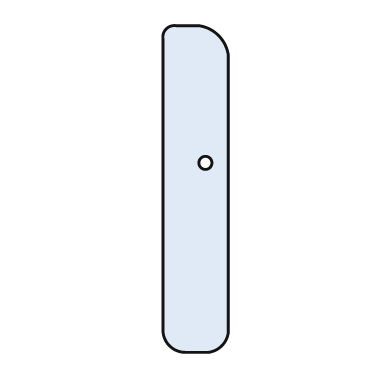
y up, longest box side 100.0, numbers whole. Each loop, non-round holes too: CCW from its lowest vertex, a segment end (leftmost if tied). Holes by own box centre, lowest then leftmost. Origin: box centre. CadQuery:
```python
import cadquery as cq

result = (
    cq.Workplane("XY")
    .moveTo(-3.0, -50.0)
    .lineTo(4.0, -50.0)
    .threePointArc((8.0, -48.0), (10.0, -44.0))
    .lineTo(10.0, 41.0)
    .threePointArc((7.0, 47.0), (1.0, 50.0))
    .lineTo(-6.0, 50.0)
    .threePointArc((-9.0, 49.0), (-10.0, 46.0))
    .lineTo(-10.0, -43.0)
    .threePointArc((-8.0, -48.0), (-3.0, -50.0))
    .close()
    .moveTo(3.0, 8.0)
    .circle(2.0)
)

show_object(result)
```